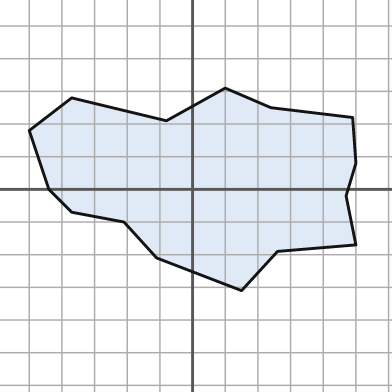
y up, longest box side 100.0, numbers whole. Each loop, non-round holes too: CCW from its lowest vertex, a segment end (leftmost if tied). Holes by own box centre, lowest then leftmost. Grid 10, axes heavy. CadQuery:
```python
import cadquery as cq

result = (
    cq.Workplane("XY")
    .moveTo(15.0, -31.0)
    .lineTo(26.0, -19.0)
    .lineTo(50.0, -17.0)
    .lineTo(47.0, -2.0)
    .lineTo(50.0, 8.0)
    .lineTo(49.0, 22.0)
    .lineTo(24.0, 25.0)
    .lineTo(10.0, 31.0)
    .lineTo(-8.0, 21.0)
    .lineTo(-37.0, 28.0)
    .lineTo(-50.0, 18.0)
    .lineTo(-44.0, 0.0)
    .lineTo(-37.0, -7.0)
    .lineTo(-21.0, -10.0)
    .lineTo(-11.0, -21.0)
    .close()
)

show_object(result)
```